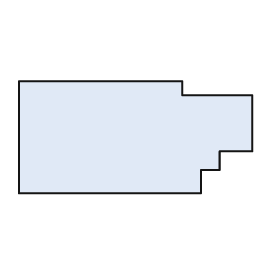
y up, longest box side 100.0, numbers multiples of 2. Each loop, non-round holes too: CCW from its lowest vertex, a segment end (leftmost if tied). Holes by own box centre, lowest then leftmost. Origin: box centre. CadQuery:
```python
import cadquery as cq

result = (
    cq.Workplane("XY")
    .moveTo(-50.0, -24.0)
    .lineTo(28.0, -24.0)
    .lineTo(28.0, -14.0)
    .lineTo(36.0, -14.0)
    .lineTo(36.0, -6.0)
    .lineTo(50.0, -6.0)
    .lineTo(50.0, 18.0)
    .lineTo(20.0, 18.0)
    .lineTo(20.0, 24.0)
    .lineTo(-50.0, 24.0)
    .close()
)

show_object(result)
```